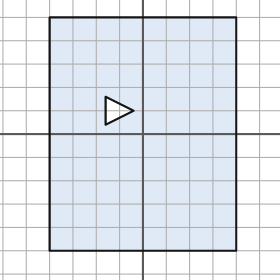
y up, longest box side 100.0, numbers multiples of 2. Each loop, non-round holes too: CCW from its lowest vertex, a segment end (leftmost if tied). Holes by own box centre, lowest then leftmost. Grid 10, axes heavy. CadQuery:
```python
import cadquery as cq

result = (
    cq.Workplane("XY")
    .moveTo(-40.0, -50.0)
    .lineTo(40.0, -50.0)
    .lineTo(40.0, 50.0)
    .lineTo(-40.0, 50.0)
    .close()
    .moveTo(-16.0, 4.0)
    .lineTo(-4.0, 10.0)
    .lineTo(-16.0, 16.0)
    .close()
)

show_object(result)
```